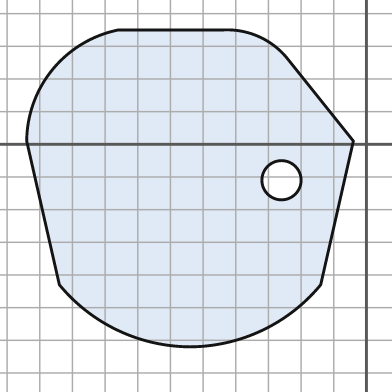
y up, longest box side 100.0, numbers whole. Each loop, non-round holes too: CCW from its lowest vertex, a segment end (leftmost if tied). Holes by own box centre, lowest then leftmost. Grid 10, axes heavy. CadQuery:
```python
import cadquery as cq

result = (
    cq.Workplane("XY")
    .moveTo(-54.0, -62.0)
    .threePointArc((-32.0, -57.0), (-14.0, -43.0))
    .lineTo(-4.0, 1.0)
    .lineTo(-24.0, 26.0)
    .threePointArc((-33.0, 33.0), (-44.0, 35.0))
    .lineTo(-76.0, 35.0)
    .threePointArc((-96.0, 23.0), (-104.0, 1.0))
    .lineTo(-94.0, -43.0)
    .threePointArc((-76.0, -57.0), (-54.0, -62.0))
    .close()
    .moveTo(-26.0, -11.0)
    .circle(6.0)
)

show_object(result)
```